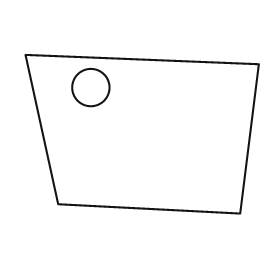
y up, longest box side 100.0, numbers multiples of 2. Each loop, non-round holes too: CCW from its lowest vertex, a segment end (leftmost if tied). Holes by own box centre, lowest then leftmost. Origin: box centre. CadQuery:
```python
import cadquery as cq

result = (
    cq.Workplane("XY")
    .moveTo(42.0, -34.0)
    .lineTo(50.0, 30.0)
    .lineTo(-50.0, 34.0)
    .lineTo(-36.0, -30.0)
    .close()
    .moveTo(-22.0, 20.0)
    .circle(8.0)
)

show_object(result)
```